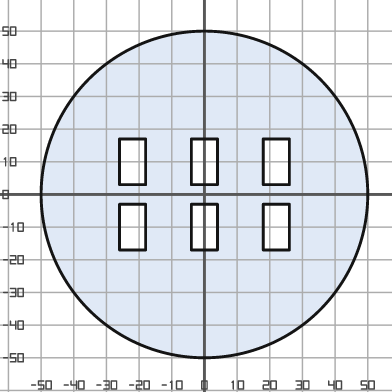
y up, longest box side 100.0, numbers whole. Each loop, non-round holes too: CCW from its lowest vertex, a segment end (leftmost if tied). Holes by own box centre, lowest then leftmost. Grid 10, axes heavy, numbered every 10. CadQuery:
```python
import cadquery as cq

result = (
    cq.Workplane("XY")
    .moveTo(0.0, 0.0)
    .circle(50.0)
    .moveTo(-26.0, -17.0)
    .lineTo(-18.0, -17.0)
    .lineTo(-18.0, -3.0)
    .lineTo(-26.0, -3.0)
    .close()
    .moveTo(-4.0, -17.0)
    .lineTo(4.0, -17.0)
    .lineTo(4.0, -3.0)
    .lineTo(-4.0, -3.0)
    .close()
    .moveTo(18.0, -17.0)
    .lineTo(26.0, -17.0)
    .lineTo(26.0, -3.0)
    .lineTo(18.0, -3.0)
    .close()
    .moveTo(-26.0, 3.0)
    .lineTo(-18.0, 3.0)
    .lineTo(-18.0, 17.0)
    .lineTo(-26.0, 17.0)
    .close()
    .moveTo(-4.0, 3.0)
    .lineTo(4.0, 3.0)
    .lineTo(4.0, 17.0)
    .lineTo(-4.0, 17.0)
    .close()
    .moveTo(18.0, 3.0)
    .lineTo(26.0, 3.0)
    .lineTo(26.0, 17.0)
    .lineTo(18.0, 17.0)
    .close()
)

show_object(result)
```